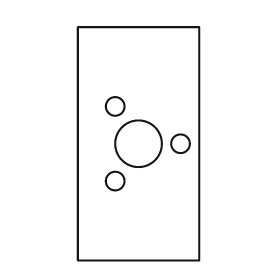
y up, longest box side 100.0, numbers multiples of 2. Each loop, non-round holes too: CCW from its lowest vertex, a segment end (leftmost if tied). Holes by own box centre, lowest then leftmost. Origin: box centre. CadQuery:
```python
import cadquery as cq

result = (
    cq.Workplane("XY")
    .moveTo(-26.0, -50.0)
    .lineTo(26.0, -50.0)
    .lineTo(26.0, 50.0)
    .lineTo(-26.0, 50.0)
    .close()
    .moveTo(-10.0, -16.0)
    .circle(4.0)
    .moveTo(0.0, 0.0)
    .circle(10.0)
    .moveTo(18.0, 0.0)
    .circle(4.0)
    .moveTo(-10.0, 16.0)
    .circle(4.0)
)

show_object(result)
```